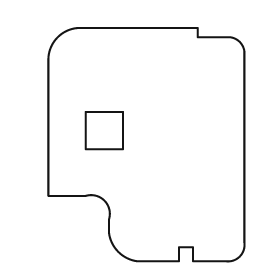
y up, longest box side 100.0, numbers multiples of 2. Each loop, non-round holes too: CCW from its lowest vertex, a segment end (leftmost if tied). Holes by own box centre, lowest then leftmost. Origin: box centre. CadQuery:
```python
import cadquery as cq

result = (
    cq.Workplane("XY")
    .moveTo(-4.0, -50.0)
    .lineTo(14.0, -50.0)
    .lineTo(14.0, -44.0)
    .lineTo(20.0, -44.0)
    .lineTo(20.0, -50.0)
    .lineTo(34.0, -50.0)
    .threePointArc((40.0, -48.0), (42.0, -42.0))
    .lineTo(42.0, 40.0)
    .threePointArc((40.0, 44.0), (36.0, 46.0))
    .lineTo(22.0, 46.0)
    .lineTo(22.0, 50.0)
    .lineTo(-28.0, 50.0)
    .threePointArc((-38.0, 46.0), (-42.0, 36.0))
    .lineTo(-42.0, -22.0)
    .lineTo(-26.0, -22.0)
    .threePointArc((-18.0, -24.0), (-16.0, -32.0))
    .lineTo(-16.0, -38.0)
    .threePointArc((-12.0, -46.0), (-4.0, -50.0))
    .close()
    .moveTo(-26.0, -2.0)
    .lineTo(-10.0, -2.0)
    .lineTo(-10.0, 14.0)
    .lineTo(-26.0, 14.0)
    .close()
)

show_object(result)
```